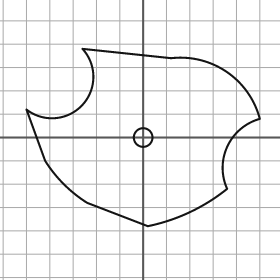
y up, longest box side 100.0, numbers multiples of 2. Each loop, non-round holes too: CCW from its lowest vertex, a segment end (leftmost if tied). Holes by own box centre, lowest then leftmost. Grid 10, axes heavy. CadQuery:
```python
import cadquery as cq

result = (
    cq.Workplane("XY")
    .moveTo(2.0, -38.0)
    .threePointArc((20.0, -32.0), (36.0, -22.0))
    .threePointArc((36.0, -4.0), (50.0, 8.0))
    .threePointArc((36.0, 28.0), (12.0, 34.0))
    .lineTo(-26.0, 38.0)
    .threePointArc((-26.0, 14.0), (-50.0, 12.0))
    .lineTo(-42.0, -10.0)
    .threePointArc((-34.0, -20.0), (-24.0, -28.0))
    .close()
    .moveTo(0.0, 0.0)
    .circle(4.0)
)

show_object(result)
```